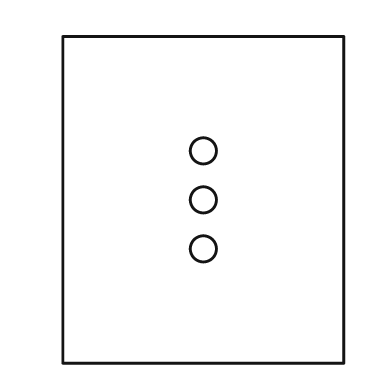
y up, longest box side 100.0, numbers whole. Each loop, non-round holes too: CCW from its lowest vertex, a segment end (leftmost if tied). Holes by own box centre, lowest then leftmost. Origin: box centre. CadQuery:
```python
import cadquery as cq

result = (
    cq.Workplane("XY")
    .moveTo(-43.0, -50.0)
    .lineTo(43.0, -50.0)
    .lineTo(43.0, 50.0)
    .lineTo(-43.0, 50.0)
    .close()
    .moveTo(0.0, -15.0)
    .circle(4.0)
    .moveTo(0.0, 0.0)
    .circle(4.0)
    .moveTo(0.0, 15.0)
    .circle(4.0)
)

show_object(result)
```